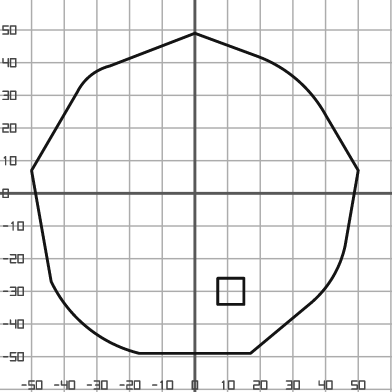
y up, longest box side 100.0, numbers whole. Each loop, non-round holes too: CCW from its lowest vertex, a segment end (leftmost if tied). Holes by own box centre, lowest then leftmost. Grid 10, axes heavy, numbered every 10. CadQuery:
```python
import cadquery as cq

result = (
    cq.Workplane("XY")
    .moveTo(-17.0, -49.0)
    .lineTo(17.0, -49.0)
    .lineTo(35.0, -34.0)
    .threePointArc((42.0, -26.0), (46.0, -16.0))
    .lineTo(50.0, 7.0)
    .lineTo(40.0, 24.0)
    .threePointArc((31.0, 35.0), (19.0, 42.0))
    .lineTo(0.0, 49.0)
    .lineTo(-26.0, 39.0)
    .threePointArc((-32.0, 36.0), (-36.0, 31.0))
    .lineTo(-50.0, 7.0)
    .lineTo(-44.0, -27.0)
    .threePointArc((-33.0, -41.0), (-17.0, -49.0))
    .close()
    .moveTo(7.0, -34.0)
    .lineTo(15.0, -34.0)
    .lineTo(15.0, -26.0)
    .lineTo(7.0, -26.0)
    .close()
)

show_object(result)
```